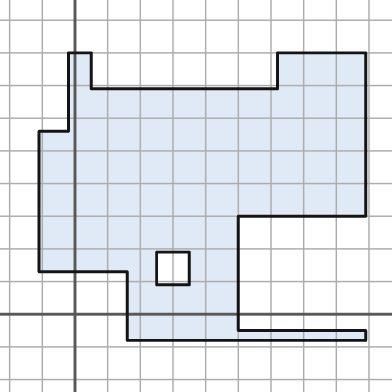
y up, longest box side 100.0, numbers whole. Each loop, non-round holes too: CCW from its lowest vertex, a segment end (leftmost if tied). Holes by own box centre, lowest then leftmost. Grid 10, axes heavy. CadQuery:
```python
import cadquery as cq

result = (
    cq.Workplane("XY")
    .moveTo(16.0, -8.0)
    .lineTo(89.0, -8.0)
    .lineTo(89.0, -5.0)
    .lineTo(50.0, -5.0)
    .lineTo(50.0, 30.0)
    .lineTo(89.0, 30.0)
    .lineTo(89.0, 80.0)
    .lineTo(62.0, 80.0)
    .lineTo(62.0, 69.0)
    .lineTo(5.0, 69.0)
    .lineTo(5.0, 80.0)
    .lineTo(-2.0, 80.0)
    .lineTo(-2.0, 56.0)
    .lineTo(-11.0, 56.0)
    .lineTo(-11.0, 13.0)
    .lineTo(16.0, 13.0)
    .close()
    .moveTo(25.0, 9.0)
    .lineTo(35.0, 9.0)
    .lineTo(35.0, 19.0)
    .lineTo(25.0, 19.0)
    .close()
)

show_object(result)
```